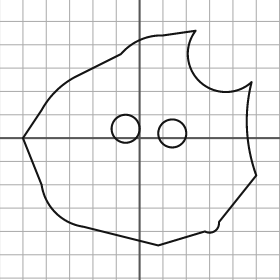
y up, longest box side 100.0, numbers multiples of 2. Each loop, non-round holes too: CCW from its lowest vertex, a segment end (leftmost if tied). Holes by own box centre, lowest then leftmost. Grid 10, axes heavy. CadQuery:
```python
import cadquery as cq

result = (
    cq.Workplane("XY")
    .moveTo(8.0, -46.0)
    .lineTo(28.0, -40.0)
    .threePointArc((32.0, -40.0), (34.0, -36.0))
    .lineTo(50.0, -16.0)
    .threePointArc((46.0, 4.0), (48.0, 24.0))
    .threePointArc((26.0, 24.0), (24.0, 46.0))
    .lineTo(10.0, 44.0)
    .threePointArc((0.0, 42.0), (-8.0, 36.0))
    .lineTo(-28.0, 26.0)
    .threePointArc((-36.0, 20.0), (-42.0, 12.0))
    .lineTo(-50.0, 0.0)
    .lineTo(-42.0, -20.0)
    .threePointArc((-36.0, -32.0), (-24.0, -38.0))
    .close()
    .moveTo(14.0, 2.0)
    .circle(6.0)
    .moveTo(-6.0, 4.0)
    .circle(6.0)
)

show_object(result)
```